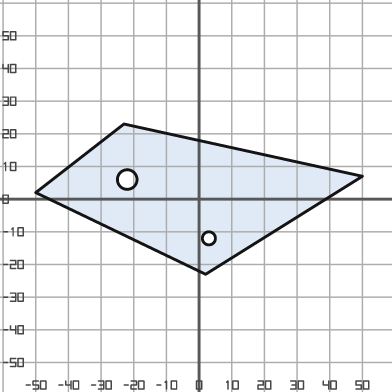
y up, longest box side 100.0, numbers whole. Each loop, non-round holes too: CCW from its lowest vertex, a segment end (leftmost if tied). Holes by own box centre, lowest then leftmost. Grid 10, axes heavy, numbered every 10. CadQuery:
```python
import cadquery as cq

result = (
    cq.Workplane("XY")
    .moveTo(2.0, -23.0)
    .lineTo(50.0, 7.0)
    .lineTo(-23.0, 23.0)
    .lineTo(-50.0, 2.0)
    .close()
    .moveTo(3.0, -12.0)
    .circle(2.0)
    .moveTo(-22.0, 6.0)
    .circle(3.0)
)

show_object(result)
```